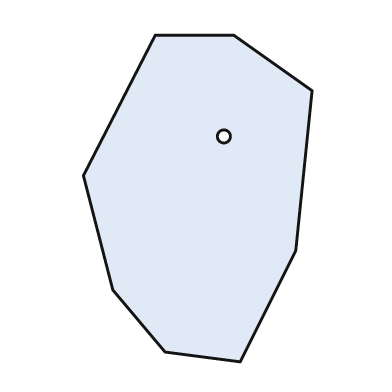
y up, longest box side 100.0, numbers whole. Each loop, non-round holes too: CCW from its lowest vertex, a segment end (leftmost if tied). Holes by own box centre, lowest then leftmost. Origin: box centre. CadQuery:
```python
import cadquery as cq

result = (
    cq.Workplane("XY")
    .moveTo(13.0, -50.0)
    .lineTo(30.0, -16.0)
    .lineTo(35.0, 33.0)
    .lineTo(11.0, 50.0)
    .lineTo(-13.0, 50.0)
    .lineTo(-35.0, 7.0)
    .lineTo(-26.0, -28.0)
    .lineTo(-10.0, -47.0)
    .close()
    .moveTo(8.0, 19.0)
    .circle(2.0)
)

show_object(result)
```